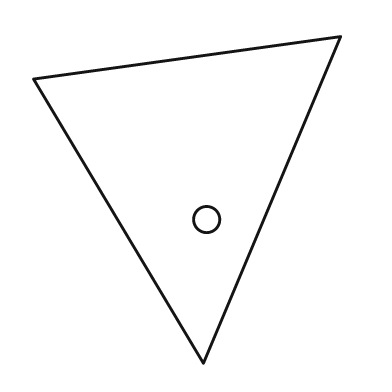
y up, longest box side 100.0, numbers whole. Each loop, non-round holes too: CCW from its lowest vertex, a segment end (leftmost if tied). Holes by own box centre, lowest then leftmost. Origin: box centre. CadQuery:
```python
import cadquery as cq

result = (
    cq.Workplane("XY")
    .moveTo(5.0, -50.0)
    .lineTo(47.0, 50.0)
    .lineTo(-47.0, 37.0)
    .close()
    .moveTo(6.0, -6.0)
    .circle(4.0)
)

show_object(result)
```